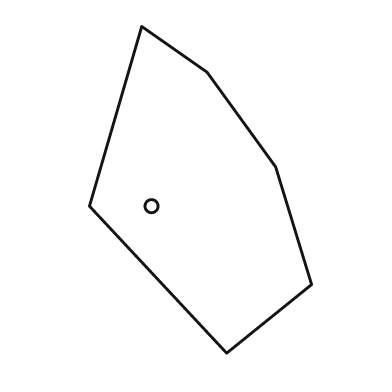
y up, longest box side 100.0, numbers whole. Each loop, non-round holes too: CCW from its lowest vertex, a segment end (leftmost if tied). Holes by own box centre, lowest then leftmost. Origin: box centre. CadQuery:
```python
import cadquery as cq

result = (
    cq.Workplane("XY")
    .moveTo(8.0, -50.0)
    .lineTo(34.0, -29.0)
    .lineTo(23.0, 7.0)
    .lineTo(2.0, 36.0)
    .lineTo(-18.0, 50.0)
    .lineTo(-34.0, -5.0)
    .close()
    .moveTo(-15.0, -5.0)
    .circle(2.0)
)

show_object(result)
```